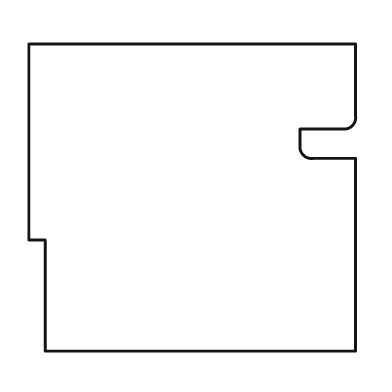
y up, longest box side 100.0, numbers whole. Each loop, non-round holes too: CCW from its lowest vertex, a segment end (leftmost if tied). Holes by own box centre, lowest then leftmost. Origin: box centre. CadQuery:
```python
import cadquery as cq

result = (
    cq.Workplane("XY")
    .moveTo(-45.0, -47.0)
    .lineTo(50.0, -47.0)
    .lineTo(50.0, 12.0)
    .lineTo(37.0, 12.0)
    .threePointArc((34.0, 13.0), (33.0, 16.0))
    .lineTo(33.0, 21.0)
    .lineTo(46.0, 21.0)
    .threePointArc((49.0, 22.0), (50.0, 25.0))
    .lineTo(50.0, 47.0)
    .lineTo(-50.0, 47.0)
    .lineTo(-50.0, -13.0)
    .lineTo(-45.0, -13.0)
    .close()
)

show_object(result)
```